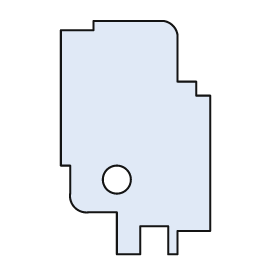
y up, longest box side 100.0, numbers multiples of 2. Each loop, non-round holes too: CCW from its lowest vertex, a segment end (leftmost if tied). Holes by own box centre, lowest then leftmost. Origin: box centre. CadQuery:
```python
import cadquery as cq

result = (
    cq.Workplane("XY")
    .moveTo(-8.0, -50.0)
    .lineTo(2.0, -50.0)
    .lineTo(2.0, -38.0)
    .lineTo(14.0, -38.0)
    .lineTo(14.0, -50.0)
    .lineTo(18.0, -50.0)
    .lineTo(18.0, -40.0)
    .lineTo(32.0, -40.0)
    .lineTo(32.0, 18.0)
    .lineTo(26.0, 18.0)
    .lineTo(26.0, 24.0)
    .lineTo(18.0, 24.0)
    .lineTo(18.0, 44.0)
    .threePointArc((16.0, 48.0), (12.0, 50.0))
    .lineTo(-18.0, 50.0)
    .lineTo(-18.0, 46.0)
    .lineTo(-32.0, 46.0)
    .lineTo(-32.0, -12.0)
    .lineTo(-28.0, -12.0)
    .lineTo(-28.0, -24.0)
    .threePointArc((-26.0, -30.0), (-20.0, -32.0))
    .lineTo(-8.0, -32.0)
    .close()
    .moveTo(-8.0, -18.0)
    .circle(6.0)
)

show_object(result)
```